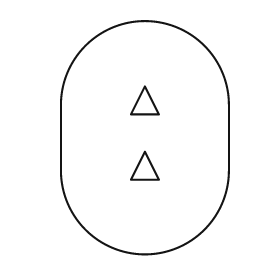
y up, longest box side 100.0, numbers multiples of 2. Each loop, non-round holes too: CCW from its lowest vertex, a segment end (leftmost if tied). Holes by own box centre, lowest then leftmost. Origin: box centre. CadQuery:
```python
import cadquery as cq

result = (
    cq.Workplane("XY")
    .moveTo(-36.0, -14.0)
    .threePointArc((0.0, -50.0), (36.0, -14.0))
    .lineTo(36.0, 14.0)
    .threePointArc((0.0, 50.0), (-36.0, 14.0))
    .close()
    .moveTo(-6.0, -18.0)
    .lineTo(6.0, -18.0)
    .lineTo(0.0, -6.0)
    .close()
    .moveTo(-6.0, 10.0)
    .lineTo(6.0, 10.0)
    .lineTo(0.0, 22.0)
    .close()
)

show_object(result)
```